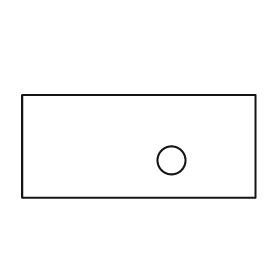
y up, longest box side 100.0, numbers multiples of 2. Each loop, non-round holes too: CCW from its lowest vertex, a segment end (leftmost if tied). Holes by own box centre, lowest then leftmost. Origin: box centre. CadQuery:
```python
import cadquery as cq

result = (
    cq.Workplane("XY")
    .moveTo(-50.0, -22.0)
    .lineTo(50.0, -22.0)
    .lineTo(50.0, 22.0)
    .lineTo(-50.0, 22.0)
    .close()
    .moveTo(14.0, -6.0)
    .circle(6.0)
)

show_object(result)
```